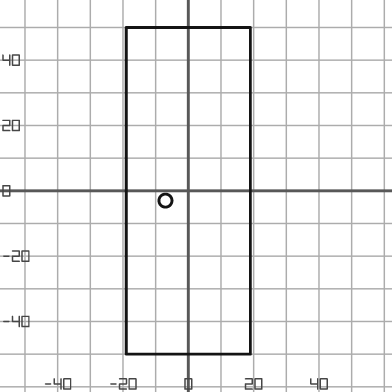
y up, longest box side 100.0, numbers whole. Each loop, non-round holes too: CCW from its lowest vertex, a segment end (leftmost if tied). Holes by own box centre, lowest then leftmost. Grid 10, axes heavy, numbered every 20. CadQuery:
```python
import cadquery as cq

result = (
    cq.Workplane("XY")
    .moveTo(-19.0, -50.0)
    .lineTo(19.0, -50.0)
    .lineTo(19.0, 50.0)
    .lineTo(-19.0, 50.0)
    .close()
    .moveTo(-7.0, -3.0)
    .circle(2.0)
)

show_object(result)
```